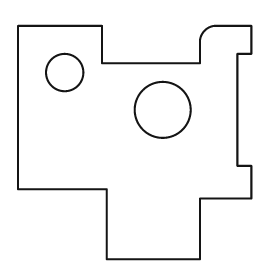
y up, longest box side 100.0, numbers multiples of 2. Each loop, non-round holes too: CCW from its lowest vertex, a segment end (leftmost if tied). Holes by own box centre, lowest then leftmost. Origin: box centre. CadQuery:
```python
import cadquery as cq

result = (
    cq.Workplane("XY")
    .moveTo(-12.0, -50.0)
    .lineTo(28.0, -50.0)
    .lineTo(28.0, -24.0)
    .lineTo(50.0, -24.0)
    .lineTo(50.0, -10.0)
    .lineTo(44.0, -10.0)
    .lineTo(44.0, 38.0)
    .lineTo(50.0, 38.0)
    .lineTo(50.0, 50.0)
    .lineTo(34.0, 50.0)
    .threePointArc((30.0, 48.0), (28.0, 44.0))
    .lineTo(28.0, 34.0)
    .lineTo(-14.0, 34.0)
    .lineTo(-14.0, 50.0)
    .lineTo(-50.0, 50.0)
    .lineTo(-50.0, -20.0)
    .lineTo(-12.0, -20.0)
    .close()
    .moveTo(12.0, 14.0)
    .circle(12.0)
    .moveTo(-30.0, 30.0)
    .circle(8.0)
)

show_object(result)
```